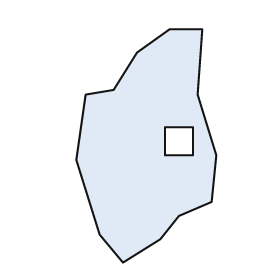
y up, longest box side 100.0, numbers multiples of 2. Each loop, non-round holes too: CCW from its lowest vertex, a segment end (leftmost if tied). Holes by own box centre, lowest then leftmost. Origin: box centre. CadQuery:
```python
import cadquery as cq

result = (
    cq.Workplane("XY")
    .moveTo(-10.0, -50.0)
    .lineTo(6.0, -40.0)
    .lineTo(14.0, -30.0)
    .lineTo(28.0, -24.0)
    .lineTo(30.0, -4.0)
    .lineTo(22.0, 22.0)
    .lineTo(24.0, 50.0)
    .lineTo(10.0, 50.0)
    .lineTo(-4.0, 40.0)
    .lineTo(-14.0, 24.0)
    .lineTo(-26.0, 22.0)
    .lineTo(-30.0, -6.0)
    .lineTo(-20.0, -38.0)
    .close()
    .moveTo(8.0, -4.0)
    .lineTo(20.0, -4.0)
    .lineTo(20.0, 8.0)
    .lineTo(8.0, 8.0)
    .close()
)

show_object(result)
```